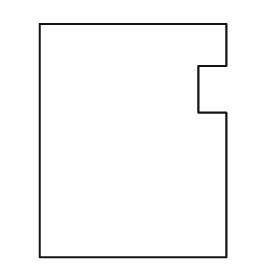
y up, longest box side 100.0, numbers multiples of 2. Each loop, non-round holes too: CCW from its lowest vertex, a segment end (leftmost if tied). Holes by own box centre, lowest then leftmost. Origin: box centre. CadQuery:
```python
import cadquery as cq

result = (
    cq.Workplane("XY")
    .moveTo(-40.0, -50.0)
    .lineTo(40.0, -50.0)
    .lineTo(40.0, 12.0)
    .lineTo(28.0, 12.0)
    .lineTo(28.0, 32.0)
    .lineTo(40.0, 32.0)
    .lineTo(40.0, 50.0)
    .lineTo(-40.0, 50.0)
    .close()
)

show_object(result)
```